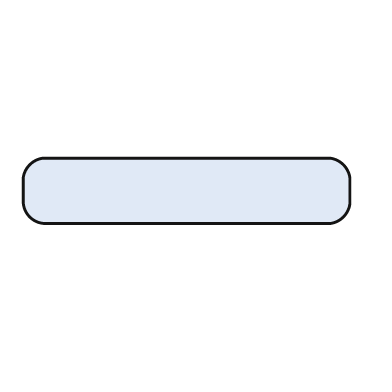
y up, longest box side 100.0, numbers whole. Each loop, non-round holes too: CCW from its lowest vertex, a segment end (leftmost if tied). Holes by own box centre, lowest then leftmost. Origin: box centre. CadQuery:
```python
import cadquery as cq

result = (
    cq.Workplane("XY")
    .moveTo(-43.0, -10.0)
    .lineTo(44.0, -10.0)
    .threePointArc((48.0, -8.0), (50.0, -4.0))
    .lineTo(50.0, 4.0)
    .threePointArc((48.0, 8.0), (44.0, 10.0))
    .lineTo(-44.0, 10.0)
    .threePointArc((-48.0, 8.0), (-50.0, 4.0))
    .lineTo(-50.0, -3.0)
    .threePointArc((-48.0, -8.0), (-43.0, -10.0))
    .close()
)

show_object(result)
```